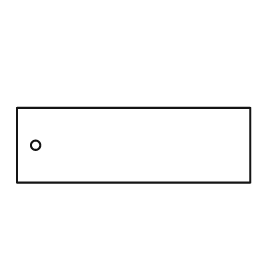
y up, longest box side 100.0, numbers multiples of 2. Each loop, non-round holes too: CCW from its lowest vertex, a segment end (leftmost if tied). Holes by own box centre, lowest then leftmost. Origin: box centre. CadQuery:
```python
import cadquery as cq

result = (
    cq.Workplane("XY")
    .moveTo(-50.0, -16.0)
    .lineTo(50.0, -16.0)
    .lineTo(50.0, 16.0)
    .lineTo(-50.0, 16.0)
    .close()
    .moveTo(-42.0, 0.0)
    .circle(2.0)
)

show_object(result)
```